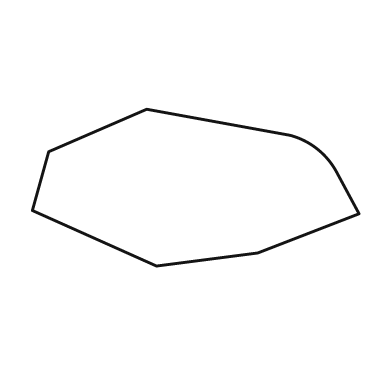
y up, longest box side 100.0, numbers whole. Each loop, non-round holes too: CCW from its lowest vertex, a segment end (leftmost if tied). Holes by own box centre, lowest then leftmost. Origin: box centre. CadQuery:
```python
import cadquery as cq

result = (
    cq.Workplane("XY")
    .moveTo(-12.0, -24.0)
    .lineTo(19.0, -20.0)
    .lineTo(50.0, -8.0)
    .lineTo(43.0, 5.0)
    .threePointArc((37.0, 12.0), (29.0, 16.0))
    .lineTo(-15.0, 24.0)
    .lineTo(-45.0, 11.0)
    .lineTo(-50.0, -7.0)
    .close()
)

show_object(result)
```